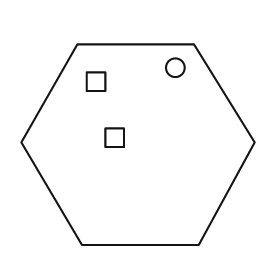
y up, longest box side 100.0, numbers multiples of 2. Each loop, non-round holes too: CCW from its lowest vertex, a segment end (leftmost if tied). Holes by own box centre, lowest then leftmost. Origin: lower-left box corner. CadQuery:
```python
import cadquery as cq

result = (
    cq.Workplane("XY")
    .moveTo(26.0, 0.0)
    .lineTo(76.0, 0.0)
    .lineTo(100.0, 44.0)
    .lineTo(74.0, 86.0)
    .lineTo(24.0, 86.0)
    .lineTo(0.0, 44.0)
    .close()
    .moveTo(36.0, 42.0)
    .lineTo(44.0, 42.0)
    .lineTo(44.0, 50.0)
    .lineTo(36.0, 50.0)
    .close()
    .moveTo(28.0, 66.0)
    .lineTo(36.0, 66.0)
    .lineTo(36.0, 74.0)
    .lineTo(28.0, 74.0)
    .close()
    .moveTo(66.0, 76.0)
    .circle(4.0)
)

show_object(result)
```